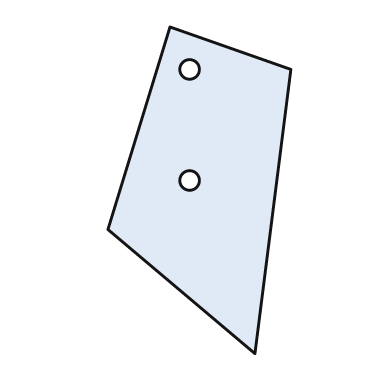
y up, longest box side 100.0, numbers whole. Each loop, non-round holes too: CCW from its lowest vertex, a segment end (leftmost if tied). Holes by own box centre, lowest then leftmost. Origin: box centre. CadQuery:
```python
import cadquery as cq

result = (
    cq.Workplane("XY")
    .moveTo(17.0, -50.0)
    .lineTo(28.0, 37.0)
    .lineTo(-9.0, 50.0)
    .lineTo(-28.0, -12.0)
    .close()
    .moveTo(-3.0, 3.0)
    .circle(3.0)
    .moveTo(-3.0, 37.0)
    .circle(3.0)
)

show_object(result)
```